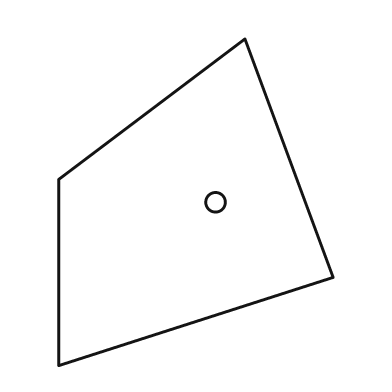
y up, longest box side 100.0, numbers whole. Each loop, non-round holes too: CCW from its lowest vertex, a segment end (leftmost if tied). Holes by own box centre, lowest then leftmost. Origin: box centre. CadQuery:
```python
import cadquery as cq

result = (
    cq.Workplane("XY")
    .moveTo(-42.0, -50.0)
    .lineTo(42.0, -23.0)
    .lineTo(15.0, 50.0)
    .lineTo(-42.0, 7.0)
    .close()
    .moveTo(6.0, 0.0)
    .circle(3.0)
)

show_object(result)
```